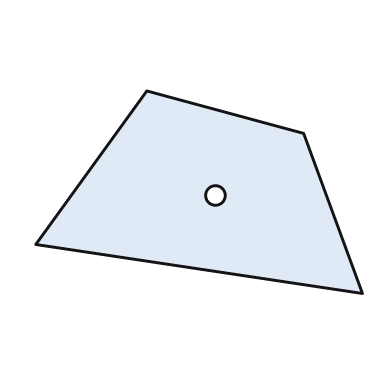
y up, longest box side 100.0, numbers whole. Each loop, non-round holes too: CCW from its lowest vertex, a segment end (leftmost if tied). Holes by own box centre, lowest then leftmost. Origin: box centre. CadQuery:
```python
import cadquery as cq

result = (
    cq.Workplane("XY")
    .moveTo(50.0, -31.0)
    .lineTo(32.0, 18.0)
    .lineTo(-16.0, 31.0)
    .lineTo(-50.0, -16.0)
    .close()
    .moveTo(5.0, -1.0)
    .circle(3.0)
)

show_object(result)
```